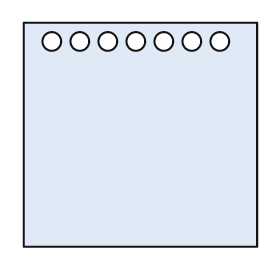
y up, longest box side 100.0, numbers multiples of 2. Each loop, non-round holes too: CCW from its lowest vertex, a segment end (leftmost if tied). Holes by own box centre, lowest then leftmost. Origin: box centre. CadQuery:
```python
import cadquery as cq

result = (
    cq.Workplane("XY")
    .moveTo(-50.0, -48.0)
    .lineTo(50.0, -48.0)
    .lineTo(50.0, 48.0)
    .lineTo(-50.0, 48.0)
    .close()
    .moveTo(-38.0, 40.0)
    .circle(4.0)
    .moveTo(-26.0, 40.0)
    .circle(4.0)
    .moveTo(-14.0, 40.0)
    .circle(4.0)
    .moveTo(-2.0, 40.0)
    .circle(4.0)
    .moveTo(10.0, 40.0)
    .circle(4.0)
    .moveTo(22.0, 40.0)
    .circle(4.0)
    .moveTo(34.0, 40.0)
    .circle(4.0)
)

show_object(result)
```